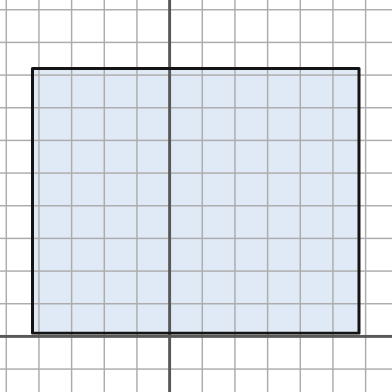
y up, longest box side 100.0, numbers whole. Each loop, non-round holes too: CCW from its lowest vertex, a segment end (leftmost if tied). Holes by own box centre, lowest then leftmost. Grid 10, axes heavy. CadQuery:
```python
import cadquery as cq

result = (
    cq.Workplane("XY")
    .moveTo(-42.0, 1.0)
    .lineTo(58.0, 1.0)
    .lineTo(58.0, 82.0)
    .lineTo(-42.0, 82.0)
    .close()
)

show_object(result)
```